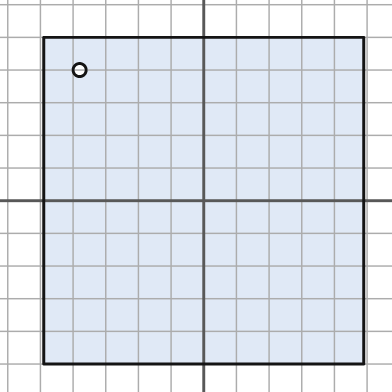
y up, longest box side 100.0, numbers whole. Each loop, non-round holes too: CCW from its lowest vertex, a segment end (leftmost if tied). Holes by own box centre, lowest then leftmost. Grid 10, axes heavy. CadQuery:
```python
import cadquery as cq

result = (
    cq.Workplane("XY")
    .moveTo(-49.0, -50.0)
    .lineTo(49.0, -50.0)
    .lineTo(49.0, 50.0)
    .lineTo(-49.0, 50.0)
    .close()
    .moveTo(-38.0, 40.0)
    .circle(2.0)
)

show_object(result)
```